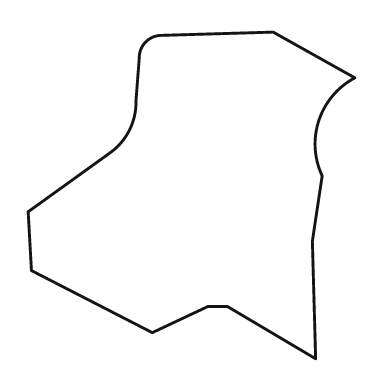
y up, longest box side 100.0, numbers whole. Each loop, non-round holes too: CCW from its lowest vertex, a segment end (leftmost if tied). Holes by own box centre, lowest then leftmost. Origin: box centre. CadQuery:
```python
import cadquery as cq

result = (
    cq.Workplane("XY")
    .moveTo(38.0, -50.0)
    .lineTo(37.0, -14.0)
    .lineTo(40.0, 6.0)
    .threePointArc((39.0, 23.0), (50.0, 36.0))
    .lineTo(25.0, 50.0)
    .lineTo(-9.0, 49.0)
    .threePointArc((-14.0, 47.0), (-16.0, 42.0))
    .lineTo(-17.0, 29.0)
    .threePointArc((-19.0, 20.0), (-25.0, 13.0))
    .lineTo(-50.0, -5.0)
    .lineTo(-49.0, -23.0)
    .lineTo(-12.0, -42.0)
    .lineTo(5.0, -34.0)
    .lineTo(11.0, -34.0)
    .close()
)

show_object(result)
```